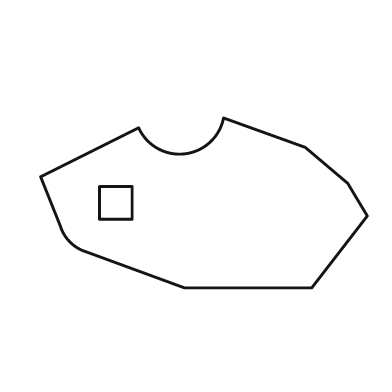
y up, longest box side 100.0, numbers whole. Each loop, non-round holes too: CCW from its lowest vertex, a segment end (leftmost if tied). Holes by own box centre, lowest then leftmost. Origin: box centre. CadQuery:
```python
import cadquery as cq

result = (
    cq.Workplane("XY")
    .moveTo(-6.0, -26.0)
    .lineTo(33.0, -26.0)
    .lineTo(50.0, -4.0)
    .lineTo(44.0, 6.0)
    .lineTo(31.0, 17.0)
    .lineTo(6.0, 26.0)
    .threePointArc((-6.0, 15.0), (-20.0, 23.0))
    .lineTo(-50.0, 8.0)
    .lineTo(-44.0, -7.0)
    .threePointArc((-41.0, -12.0), (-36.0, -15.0))
    .close()
    .moveTo(-32.0, -5.0)
    .lineTo(-22.0, -5.0)
    .lineTo(-22.0, 5.0)
    .lineTo(-32.0, 5.0)
    .close()
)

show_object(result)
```